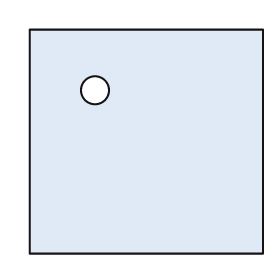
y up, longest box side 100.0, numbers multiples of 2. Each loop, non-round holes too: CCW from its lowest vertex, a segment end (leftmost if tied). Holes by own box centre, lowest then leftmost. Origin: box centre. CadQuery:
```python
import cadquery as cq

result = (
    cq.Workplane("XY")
    .moveTo(-50.0, -48.0)
    .lineTo(50.0, -48.0)
    .lineTo(50.0, 48.0)
    .lineTo(-50.0, 48.0)
    .close()
    .moveTo(-22.0, 22.0)
    .circle(6.0)
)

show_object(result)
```